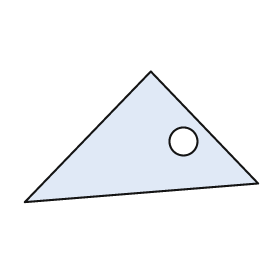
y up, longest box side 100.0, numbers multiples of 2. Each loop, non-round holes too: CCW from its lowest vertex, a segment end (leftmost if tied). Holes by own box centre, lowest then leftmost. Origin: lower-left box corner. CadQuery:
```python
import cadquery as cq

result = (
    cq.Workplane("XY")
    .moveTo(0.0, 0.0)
    .lineTo(100.0, 8.0)
    .lineTo(54.0, 56.0)
    .close()
    .moveTo(68.0, 26.0)
    .circle(6.0)
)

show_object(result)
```